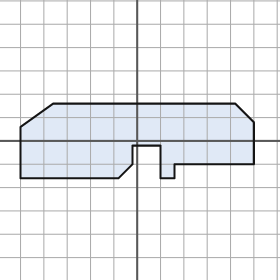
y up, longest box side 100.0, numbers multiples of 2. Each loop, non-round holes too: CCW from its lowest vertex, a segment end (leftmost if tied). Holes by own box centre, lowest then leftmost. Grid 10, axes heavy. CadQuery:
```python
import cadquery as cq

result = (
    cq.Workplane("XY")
    .moveTo(-50.0, -16.0)
    .lineTo(-8.0, -16.0)
    .lineTo(-2.0, -10.0)
    .lineTo(-2.0, -2.0)
    .lineTo(10.0, -2.0)
    .lineTo(10.0, -16.0)
    .lineTo(16.0, -16.0)
    .lineTo(16.0, -10.0)
    .lineTo(50.0, -10.0)
    .lineTo(50.0, 8.0)
    .lineTo(42.0, 16.0)
    .lineTo(-36.0, 16.0)
    .lineTo(-50.0, 6.0)
    .close()
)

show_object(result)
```